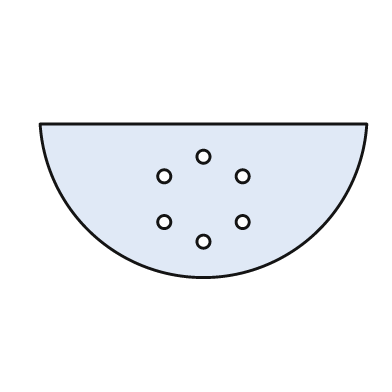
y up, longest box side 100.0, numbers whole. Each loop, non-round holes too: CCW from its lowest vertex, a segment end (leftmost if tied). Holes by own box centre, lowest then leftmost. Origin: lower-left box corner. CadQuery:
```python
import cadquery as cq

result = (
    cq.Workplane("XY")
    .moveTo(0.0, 47.0)
    .threePointArc((50.0, 0.0), (100.0, 47.0))
    .close()
    .moveTo(50.0, 11.0)
    .circle(2.0)
    .moveTo(38.0, 17.0)
    .circle(2.0)
    .moveTo(62.0, 17.0)
    .circle(2.0)
    .moveTo(38.0, 31.0)
    .circle(2.0)
    .moveTo(62.0, 31.0)
    .circle(2.0)
    .moveTo(50.0, 37.0)
    .circle(2.0)
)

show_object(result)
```